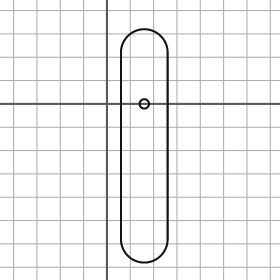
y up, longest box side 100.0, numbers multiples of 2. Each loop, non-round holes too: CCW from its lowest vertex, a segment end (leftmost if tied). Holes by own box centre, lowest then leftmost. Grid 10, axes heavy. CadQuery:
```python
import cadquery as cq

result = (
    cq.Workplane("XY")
    .moveTo(6.0, -58.0)
    .threePointArc((16.0, -68.0), (26.0, -58.0))
    .lineTo(26.0, 22.0)
    .threePointArc((16.0, 32.0), (6.0, 22.0))
    .close()
    .moveTo(16.0, 0.0)
    .circle(2.0)
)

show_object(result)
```